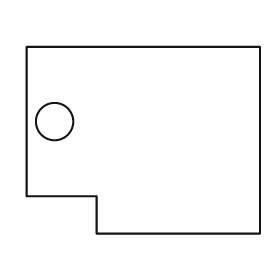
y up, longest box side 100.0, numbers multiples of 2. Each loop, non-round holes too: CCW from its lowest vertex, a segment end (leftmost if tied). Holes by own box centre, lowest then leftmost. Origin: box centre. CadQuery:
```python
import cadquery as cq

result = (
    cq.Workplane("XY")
    .moveTo(-20.0, -40.0)
    .lineTo(50.0, -40.0)
    .lineTo(50.0, 40.0)
    .lineTo(-50.0, 40.0)
    .lineTo(-50.0, -24.0)
    .lineTo(-20.0, -24.0)
    .close()
    .moveTo(-38.0, 8.0)
    .circle(8.0)
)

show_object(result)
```